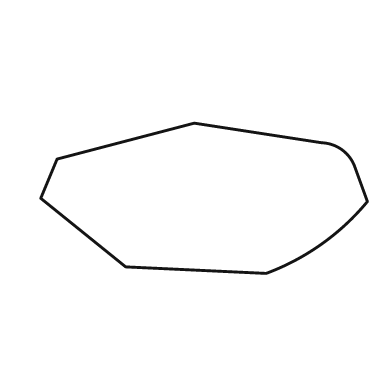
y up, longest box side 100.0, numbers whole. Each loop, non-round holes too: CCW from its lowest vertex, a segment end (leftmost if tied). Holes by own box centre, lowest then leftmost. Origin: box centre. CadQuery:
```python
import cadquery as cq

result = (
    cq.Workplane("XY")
    .moveTo(19.0, -23.0)
    .threePointArc((36.0, -14.0), (50.0, -1.0))
    .lineTo(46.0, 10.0)
    .threePointArc((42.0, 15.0), (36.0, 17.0))
    .lineTo(-3.0, 23.0)
    .lineTo(-45.0, 12.0)
    .lineTo(-50.0, 0.0)
    .lineTo(-24.0, -21.0)
    .close()
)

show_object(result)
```